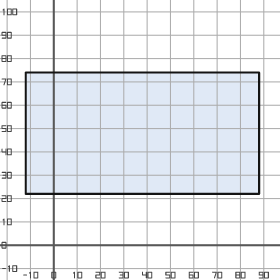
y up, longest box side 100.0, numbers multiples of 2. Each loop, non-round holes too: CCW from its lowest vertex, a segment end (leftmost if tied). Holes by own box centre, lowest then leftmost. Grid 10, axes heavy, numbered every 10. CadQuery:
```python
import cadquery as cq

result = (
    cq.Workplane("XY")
    .moveTo(-12.0, 22.0)
    .lineTo(88.0, 22.0)
    .lineTo(88.0, 74.0)
    .lineTo(-12.0, 74.0)
    .close()
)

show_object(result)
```